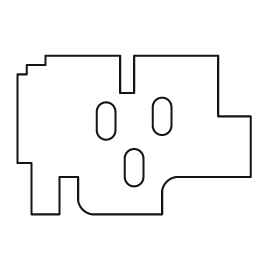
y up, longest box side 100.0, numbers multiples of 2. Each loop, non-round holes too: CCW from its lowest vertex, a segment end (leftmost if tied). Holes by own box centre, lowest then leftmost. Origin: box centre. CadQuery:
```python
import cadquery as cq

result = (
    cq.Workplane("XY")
    .moveTo(-44.0, -34.0)
    .lineTo(-32.0, -34.0)
    .lineTo(-32.0, -18.0)
    .lineTo(-24.0, -18.0)
    .lineTo(-24.0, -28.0)
    .threePointArc((-22.0, -32.0), (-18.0, -34.0))
    .lineTo(12.0, -34.0)
    .lineTo(12.0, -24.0)
    .threePointArc((14.0, -20.0), (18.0, -18.0))
    .lineTo(50.0, -18.0)
    .lineTo(50.0, 8.0)
    .lineTo(36.0, 8.0)
    .lineTo(36.0, 34.0)
    .lineTo(0.0, 34.0)
    .lineTo(0.0, 18.0)
    .lineTo(-6.0, 18.0)
    .lineTo(-6.0, 34.0)
    .lineTo(-38.0, 34.0)
    .lineTo(-38.0, 30.0)
    .lineTo(-46.0, 30.0)
    .lineTo(-46.0, 26.0)
    .lineTo(-50.0, 26.0)
    .lineTo(-50.0, -12.0)
    .lineTo(-44.0, -12.0)
    .close()
    .moveTo(-4.0, -18.0)
    .threePointArc((0.0, -22.0), (4.0, -18.0))
    .lineTo(4.0, -10.0)
    .threePointArc((0.0, -6.0), (-4.0, -10.0))
    .close()
    .moveTo(-16.0, 2.0)
    .threePointArc((-12.0, -2.0), (-8.0, 2.0))
    .lineTo(-8.0, 10.0)
    .threePointArc((-12.0, 14.0), (-16.0, 10.0))
    .close()
    .moveTo(8.0, 4.0)
    .threePointArc((12.0, 0.0), (16.0, 4.0))
    .lineTo(16.0, 12.0)
    .threePointArc((12.0, 16.0), (8.0, 12.0))
    .close()
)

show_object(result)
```